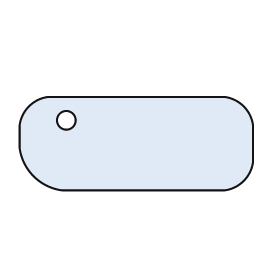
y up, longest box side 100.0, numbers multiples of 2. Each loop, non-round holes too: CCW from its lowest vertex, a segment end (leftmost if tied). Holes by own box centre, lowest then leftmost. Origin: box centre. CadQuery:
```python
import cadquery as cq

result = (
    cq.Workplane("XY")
    .moveTo(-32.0, -20.0)
    .lineTo(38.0, -20.0)
    .threePointArc((46.0, -16.0), (50.0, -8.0))
    .lineTo(50.0, 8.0)
    .threePointArc((46.0, 16.0), (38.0, 20.0))
    .lineTo(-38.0, 20.0)
    .threePointArc((-46.0, 16.0), (-50.0, 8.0))
    .lineTo(-50.0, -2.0)
    .threePointArc((-44.0, -14.0), (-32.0, -20.0))
    .close()
    .moveTo(-30.0, 10.0)
    .circle(4.0)
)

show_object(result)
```